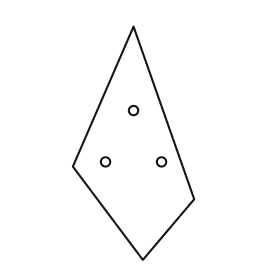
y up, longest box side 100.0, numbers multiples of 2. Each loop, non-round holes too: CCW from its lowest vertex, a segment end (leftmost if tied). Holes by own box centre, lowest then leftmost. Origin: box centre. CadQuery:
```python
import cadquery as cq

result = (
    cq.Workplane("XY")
    .moveTo(4.0, -50.0)
    .lineTo(26.0, -24.0)
    .lineTo(0.0, 50.0)
    .lineTo(-26.0, -10.0)
    .close()
    .moveTo(-12.0, -8.0)
    .circle(2.0)
    .moveTo(12.0, -8.0)
    .circle(2.0)
    .moveTo(0.0, 14.0)
    .circle(2.0)
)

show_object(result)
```